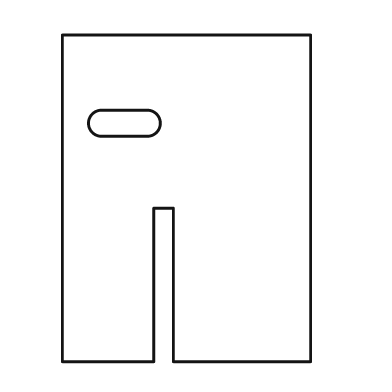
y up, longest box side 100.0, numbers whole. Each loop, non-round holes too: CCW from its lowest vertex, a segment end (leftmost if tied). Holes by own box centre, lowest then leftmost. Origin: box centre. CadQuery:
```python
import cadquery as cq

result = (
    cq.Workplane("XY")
    .moveTo(-38.0, -50.0)
    .lineTo(-10.0, -50.0)
    .lineTo(-10.0, -3.0)
    .lineTo(-4.0, -3.0)
    .lineTo(-4.0, -50.0)
    .lineTo(38.0, -50.0)
    .lineTo(38.0, 50.0)
    .lineTo(-38.0, 50.0)
    .close()
    .moveTo(-26.0, 19.0)
    .lineTo(-12.0, 19.0)
    .threePointArc((-8.0, 23.0), (-12.0, 27.0))
    .lineTo(-26.0, 27.0)
    .threePointArc((-30.0, 23.0), (-26.0, 19.0))
    .close()
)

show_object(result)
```